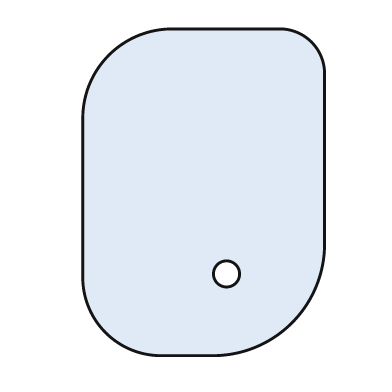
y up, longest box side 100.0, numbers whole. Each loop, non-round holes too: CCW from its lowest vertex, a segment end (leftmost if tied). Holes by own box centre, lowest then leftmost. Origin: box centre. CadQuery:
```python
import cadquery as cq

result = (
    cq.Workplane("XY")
    .moveTo(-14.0, -50.0)
    .lineTo(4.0, -50.0)
    .threePointArc((27.0, -40.0), (37.0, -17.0))
    .lineTo(37.0, 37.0)
    .threePointArc((33.0, 46.0), (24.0, 50.0))
    .lineTo(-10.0, 50.0)
    .threePointArc((-29.0, 42.0), (-37.0, 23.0))
    .lineTo(-37.0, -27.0)
    .threePointArc((-30.0, -43.0), (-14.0, -50.0))
    .close()
    .moveTo(7.0, -25.0)
    .circle(4.0)
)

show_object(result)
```